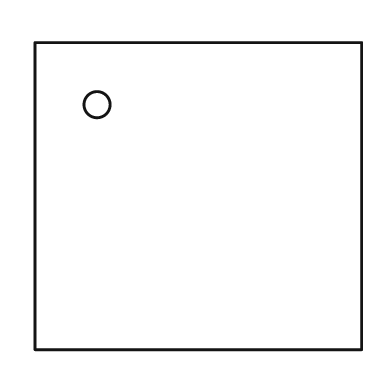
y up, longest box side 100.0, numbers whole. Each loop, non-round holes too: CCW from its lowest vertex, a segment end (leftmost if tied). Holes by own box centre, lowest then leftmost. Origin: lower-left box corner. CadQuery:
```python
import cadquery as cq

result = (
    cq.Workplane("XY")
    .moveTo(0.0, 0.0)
    .lineTo(100.0, 0.0)
    .lineTo(100.0, 94.0)
    .lineTo(0.0, 94.0)
    .close()
    .moveTo(19.0, 75.0)
    .circle(4.0)
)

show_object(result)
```